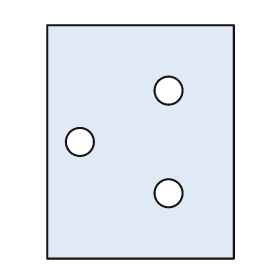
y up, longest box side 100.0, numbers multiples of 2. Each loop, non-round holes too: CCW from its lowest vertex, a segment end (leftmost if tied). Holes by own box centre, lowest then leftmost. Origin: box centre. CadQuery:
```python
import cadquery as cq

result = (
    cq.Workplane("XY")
    .moveTo(-40.0, -50.0)
    .lineTo(40.0, -50.0)
    .lineTo(40.0, 50.0)
    .lineTo(-40.0, 50.0)
    .close()
    .moveTo(12.0, -22.0)
    .circle(6.0)
    .moveTo(-26.0, 0.0)
    .circle(6.0)
    .moveTo(12.0, 22.0)
    .circle(6.0)
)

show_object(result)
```